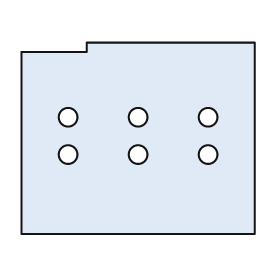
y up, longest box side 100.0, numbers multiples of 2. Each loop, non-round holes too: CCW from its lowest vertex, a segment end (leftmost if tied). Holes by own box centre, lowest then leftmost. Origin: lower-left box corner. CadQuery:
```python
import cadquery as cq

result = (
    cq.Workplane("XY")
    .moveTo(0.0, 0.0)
    .lineTo(100.0, 0.0)
    .lineTo(100.0, 82.0)
    .lineTo(28.0, 82.0)
    .lineTo(28.0, 78.0)
    .lineTo(0.0, 78.0)
    .close()
    .moveTo(20.0, 34.0)
    .circle(4.0)
    .moveTo(50.0, 34.0)
    .circle(4.0)
    .moveTo(80.0, 34.0)
    .circle(4.0)
    .moveTo(20.0, 50.0)
    .circle(4.0)
    .moveTo(50.0, 50.0)
    .circle(4.0)
    .moveTo(80.0, 50.0)
    .circle(4.0)
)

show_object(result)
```